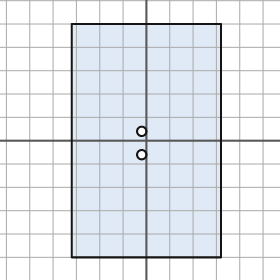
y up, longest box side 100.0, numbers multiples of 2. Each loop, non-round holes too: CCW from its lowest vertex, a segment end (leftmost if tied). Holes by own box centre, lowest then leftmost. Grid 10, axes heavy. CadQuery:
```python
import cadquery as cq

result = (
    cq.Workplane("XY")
    .moveTo(-32.0, -50.0)
    .lineTo(32.0, -50.0)
    .lineTo(32.0, 50.0)
    .lineTo(-32.0, 50.0)
    .close()
    .moveTo(-2.0, -6.0)
    .circle(2.0)
    .moveTo(-2.0, 4.0)
    .circle(2.0)
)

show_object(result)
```